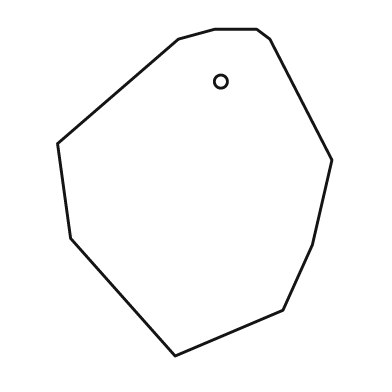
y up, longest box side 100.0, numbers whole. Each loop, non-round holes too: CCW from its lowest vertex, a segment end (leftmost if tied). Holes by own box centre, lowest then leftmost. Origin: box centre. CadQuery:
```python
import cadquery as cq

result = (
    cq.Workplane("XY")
    .moveTo(-6.0, -50.0)
    .lineTo(27.0, -36.0)
    .lineTo(36.0, -16.0)
    .lineTo(42.0, 10.0)
    .lineTo(23.0, 47.0)
    .lineTo(19.0, 50.0)
    .lineTo(6.0, 50.0)
    .lineTo(-5.0, 47.0)
    .lineTo(-42.0, 15.0)
    .lineTo(-38.0, -14.0)
    .close()
    .moveTo(8.0, 34.0)
    .circle(2.0)
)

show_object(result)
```